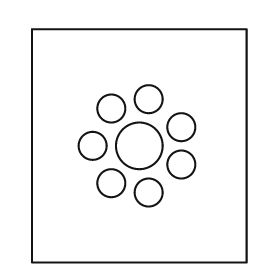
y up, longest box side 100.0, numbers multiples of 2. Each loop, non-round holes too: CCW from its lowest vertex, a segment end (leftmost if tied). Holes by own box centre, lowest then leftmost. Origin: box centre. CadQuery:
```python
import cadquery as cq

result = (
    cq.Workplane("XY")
    .moveTo(-46.0, -50.0)
    .lineTo(46.0, -50.0)
    .lineTo(46.0, 50.0)
    .lineTo(-46.0, 50.0)
    .close()
    .moveTo(4.0, -20.0)
    .circle(6.0)
    .moveTo(-12.0, -16.0)
    .circle(6.0)
    .moveTo(18.0, -8.0)
    .circle(6.0)
    .moveTo(-20.0, 0.0)
    .circle(6.0)
    .moveTo(0.0, 0.0)
    .circle(10.0)
    .moveTo(18.0, 8.0)
    .circle(6.0)
    .moveTo(-12.0, 16.0)
    .circle(6.0)
    .moveTo(4.0, 20.0)
    .circle(6.0)
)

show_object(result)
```